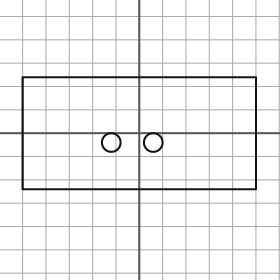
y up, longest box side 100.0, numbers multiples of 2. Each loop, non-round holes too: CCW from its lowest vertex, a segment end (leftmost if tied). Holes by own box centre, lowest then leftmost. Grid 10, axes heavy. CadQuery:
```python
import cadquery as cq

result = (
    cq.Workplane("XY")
    .moveTo(-50.0, -24.0)
    .lineTo(50.0, -24.0)
    .lineTo(50.0, 24.0)
    .lineTo(-50.0, 24.0)
    .close()
    .moveTo(-12.0, -4.0)
    .circle(4.0)
    .moveTo(6.0, -4.0)
    .circle(4.0)
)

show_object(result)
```